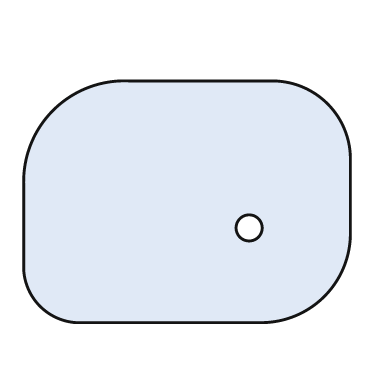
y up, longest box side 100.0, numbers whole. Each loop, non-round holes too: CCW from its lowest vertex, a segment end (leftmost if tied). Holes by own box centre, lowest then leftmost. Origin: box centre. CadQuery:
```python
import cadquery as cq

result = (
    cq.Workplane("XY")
    .moveTo(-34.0, -37.0)
    .lineTo(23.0, -37.0)
    .threePointArc((42.0, -29.0), (50.0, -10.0))
    .lineTo(50.0, 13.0)
    .threePointArc((43.0, 30.0), (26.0, 37.0))
    .lineTo(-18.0, 37.0)
    .threePointArc((-41.0, 28.0), (-50.0, 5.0))
    .lineTo(-50.0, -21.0)
    .threePointArc((-45.0, -32.0), (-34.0, -37.0))
    .close()
    .moveTo(19.0, -8.0)
    .circle(4.0)
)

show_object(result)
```